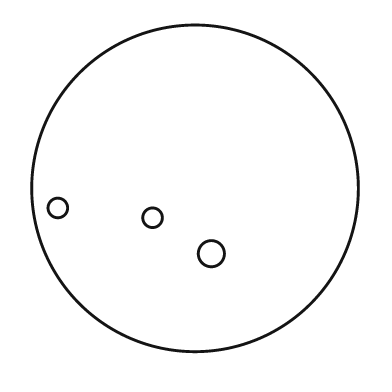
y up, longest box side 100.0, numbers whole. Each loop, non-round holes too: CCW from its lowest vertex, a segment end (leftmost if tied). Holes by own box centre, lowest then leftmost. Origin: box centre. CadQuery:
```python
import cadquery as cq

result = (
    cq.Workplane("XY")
    .moveTo(0.0, 0.0)
    .circle(50.0)
    .moveTo(5.0, -20.0)
    .circle(4.0)
    .moveTo(-13.0, -9.0)
    .circle(3.0)
    .moveTo(-42.0, -6.0)
    .circle(3.0)
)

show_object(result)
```